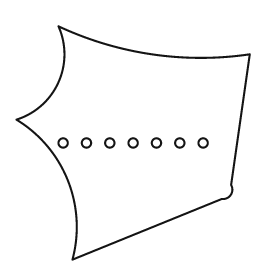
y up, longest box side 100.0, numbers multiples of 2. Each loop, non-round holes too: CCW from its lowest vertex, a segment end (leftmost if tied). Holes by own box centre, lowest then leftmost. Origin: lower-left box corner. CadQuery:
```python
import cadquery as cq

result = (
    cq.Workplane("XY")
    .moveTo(24.0, 0.0)
    .lineTo(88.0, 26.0)
    .threePointArc((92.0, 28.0), (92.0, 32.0))
    .lineTo(100.0, 88.0)
    .threePointArc((58.0, 88.0), (18.0, 100.0))
    .threePointArc((18.0, 76.0), (0.0, 60.0))
    .threePointArc((22.0, 34.0), (24.0, 0.0))
    .close()
    .moveTo(20.0, 50.0)
    .circle(2.0)
    .moveTo(30.0, 50.0)
    .circle(2.0)
    .moveTo(40.0, 50.0)
    .circle(2.0)
    .moveTo(50.0, 50.0)
    .circle(2.0)
    .moveTo(60.0, 50.0)
    .circle(2.0)
    .moveTo(70.0, 50.0)
    .circle(2.0)
    .moveTo(80.0, 50.0)
    .circle(2.0)
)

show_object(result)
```